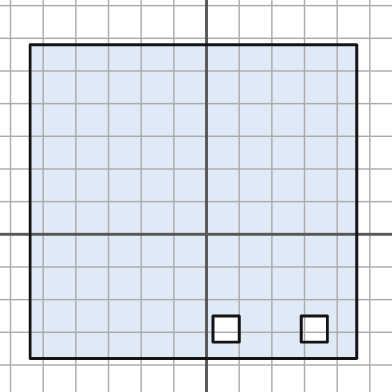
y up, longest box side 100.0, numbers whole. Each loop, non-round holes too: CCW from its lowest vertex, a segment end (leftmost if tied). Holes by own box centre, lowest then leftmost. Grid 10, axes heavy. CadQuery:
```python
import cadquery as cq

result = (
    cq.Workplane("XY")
    .moveTo(-54.0, -38.0)
    .lineTo(46.0, -38.0)
    .lineTo(46.0, 58.0)
    .lineTo(-54.0, 58.0)
    .close()
    .moveTo(2.0, -33.0)
    .lineTo(10.0, -33.0)
    .lineTo(10.0, -25.0)
    .lineTo(2.0, -25.0)
    .close()
    .moveTo(29.0, -33.0)
    .lineTo(37.0, -33.0)
    .lineTo(37.0, -25.0)
    .lineTo(29.0, -25.0)
    .close()
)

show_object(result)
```